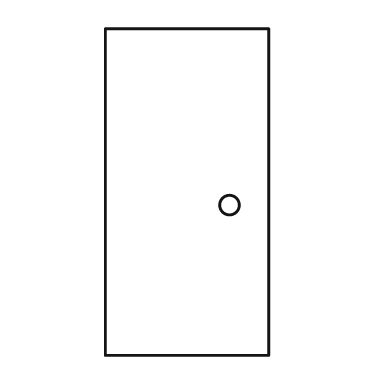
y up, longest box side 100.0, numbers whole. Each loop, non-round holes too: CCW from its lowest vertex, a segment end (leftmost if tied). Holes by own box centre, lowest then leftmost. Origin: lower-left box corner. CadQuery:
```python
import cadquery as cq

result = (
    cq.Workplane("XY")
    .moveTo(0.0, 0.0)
    .lineTo(50.0, 0.0)
    .lineTo(50.0, 100.0)
    .lineTo(0.0, 100.0)
    .close()
    .moveTo(38.0, 46.0)
    .circle(3.0)
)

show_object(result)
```